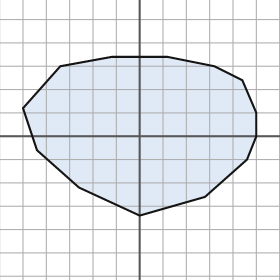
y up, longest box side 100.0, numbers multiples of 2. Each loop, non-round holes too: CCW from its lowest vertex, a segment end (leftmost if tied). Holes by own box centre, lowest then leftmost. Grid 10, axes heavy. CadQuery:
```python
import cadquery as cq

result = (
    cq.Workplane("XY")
    .moveTo(0.0, -34.0)
    .lineTo(28.0, -26.0)
    .lineTo(46.0, -10.0)
    .lineTo(50.0, 0.0)
    .lineTo(50.0, 10.0)
    .lineTo(44.0, 24.0)
    .lineTo(32.0, 30.0)
    .lineTo(12.0, 34.0)
    .lineTo(-12.0, 34.0)
    .lineTo(-34.0, 30.0)
    .lineTo(-50.0, 12.0)
    .lineTo(-44.0, -6.0)
    .lineTo(-26.0, -22.0)
    .close()
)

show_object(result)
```